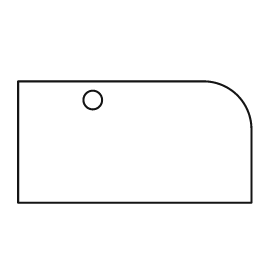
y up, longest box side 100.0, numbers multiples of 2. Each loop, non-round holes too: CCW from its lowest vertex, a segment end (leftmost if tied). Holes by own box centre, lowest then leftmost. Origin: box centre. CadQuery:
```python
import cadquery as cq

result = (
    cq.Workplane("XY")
    .moveTo(-50.0, -26.0)
    .lineTo(50.0, -26.0)
    .lineTo(50.0, 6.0)
    .threePointArc((44.0, 20.0), (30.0, 26.0))
    .lineTo(-50.0, 26.0)
    .close()
    .moveTo(-18.0, 18.0)
    .circle(4.0)
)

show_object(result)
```